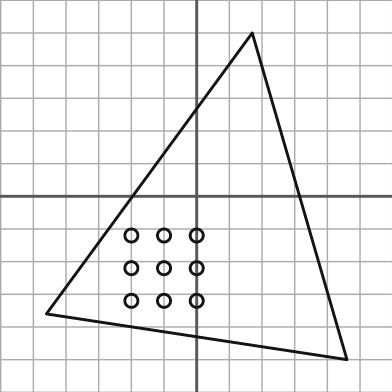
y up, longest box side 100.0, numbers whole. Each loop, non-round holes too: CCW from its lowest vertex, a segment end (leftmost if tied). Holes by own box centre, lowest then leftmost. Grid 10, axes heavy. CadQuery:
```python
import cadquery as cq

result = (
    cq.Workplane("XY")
    .moveTo(46.0, -50.0)
    .lineTo(17.0, 50.0)
    .lineTo(-46.0, -36.0)
    .close()
    .moveTo(-20.0, -32.0)
    .circle(2.0)
    .moveTo(-10.0, -32.0)
    .circle(2.0)
    .moveTo(0.0, -32.0)
    .circle(2.0)
    .moveTo(-20.0, -22.0)
    .circle(2.0)
    .moveTo(-10.0, -22.0)
    .circle(2.0)
    .moveTo(0.0, -22.0)
    .circle(2.0)
    .moveTo(-20.0, -12.0)
    .circle(2.0)
    .moveTo(-10.0, -12.0)
    .circle(2.0)
    .moveTo(0.0, -12.0)
    .circle(2.0)
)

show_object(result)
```